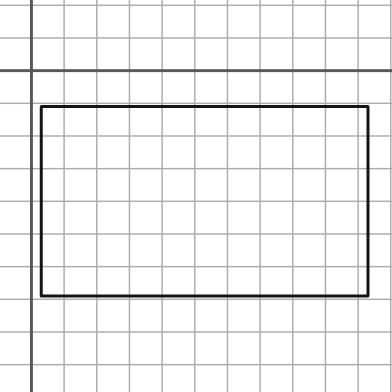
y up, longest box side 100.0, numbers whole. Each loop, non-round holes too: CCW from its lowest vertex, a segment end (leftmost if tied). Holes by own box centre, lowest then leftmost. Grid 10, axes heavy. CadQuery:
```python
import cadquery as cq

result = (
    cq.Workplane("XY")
    .moveTo(3.0, -69.0)
    .lineTo(103.0, -69.0)
    .lineTo(103.0, -11.0)
    .lineTo(3.0, -11.0)
    .close()
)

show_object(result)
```